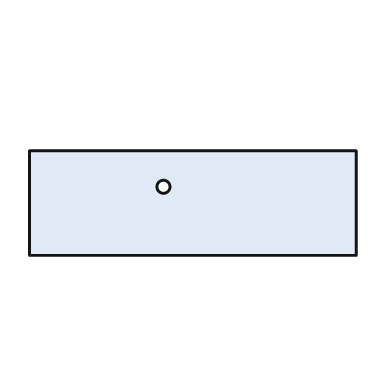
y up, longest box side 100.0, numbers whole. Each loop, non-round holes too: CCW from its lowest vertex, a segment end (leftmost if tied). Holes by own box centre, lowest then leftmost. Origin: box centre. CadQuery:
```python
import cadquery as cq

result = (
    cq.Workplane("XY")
    .moveTo(-50.0, -16.0)
    .lineTo(50.0, -16.0)
    .lineTo(50.0, 16.0)
    .lineTo(-50.0, 16.0)
    .close()
    .moveTo(-9.0, 5.0)
    .circle(2.0)
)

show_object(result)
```